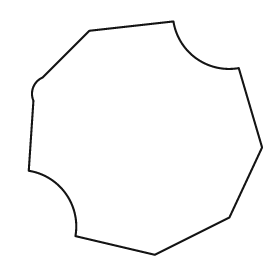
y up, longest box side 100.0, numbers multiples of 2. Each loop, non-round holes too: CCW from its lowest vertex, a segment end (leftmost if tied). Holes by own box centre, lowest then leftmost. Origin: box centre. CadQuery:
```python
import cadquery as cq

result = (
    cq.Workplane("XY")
    .moveTo(4.0, -50.0)
    .lineTo(36.0, -34.0)
    .lineTo(50.0, -4.0)
    .lineTo(40.0, 30.0)
    .threePointArc((22.0, 34.0), (12.0, 50.0))
    .lineTo(-24.0, 46.0)
    .lineTo(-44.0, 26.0)
    .threePointArc((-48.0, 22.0), (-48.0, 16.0))
    .lineTo(-50.0, -14.0)
    .threePointArc((-34.0, -24.0), (-30.0, -42.0))
    .close()
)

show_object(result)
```